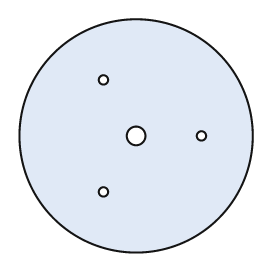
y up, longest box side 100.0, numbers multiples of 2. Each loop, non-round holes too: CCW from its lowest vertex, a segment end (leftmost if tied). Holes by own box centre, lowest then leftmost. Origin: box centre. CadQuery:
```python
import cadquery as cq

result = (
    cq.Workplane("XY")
    .moveTo(0.0, 0.0)
    .circle(50.0)
    .moveTo(-14.0, -24.0)
    .circle(2.0)
    .moveTo(0.0, 0.0)
    .circle(4.0)
    .moveTo(28.0, 0.0)
    .circle(2.0)
    .moveTo(-14.0, 24.0)
    .circle(2.0)
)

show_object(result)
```